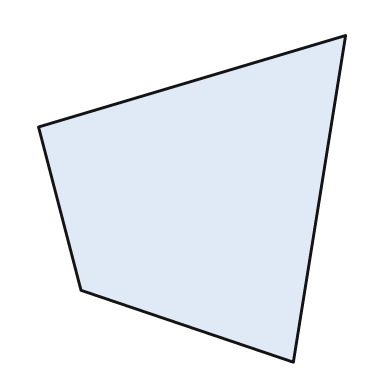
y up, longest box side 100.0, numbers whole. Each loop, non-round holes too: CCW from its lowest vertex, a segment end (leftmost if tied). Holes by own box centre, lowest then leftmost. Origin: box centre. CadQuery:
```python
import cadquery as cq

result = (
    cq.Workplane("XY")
    .moveTo(31.0, -50.0)
    .lineTo(47.0, 50.0)
    .lineTo(-47.0, 22.0)
    .lineTo(-34.0, -28.0)
    .close()
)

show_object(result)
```